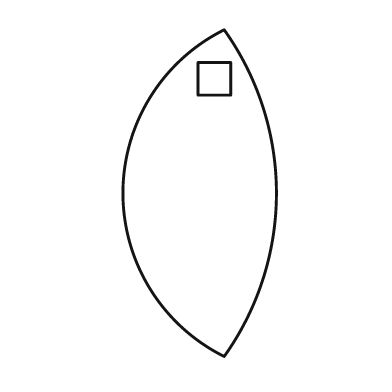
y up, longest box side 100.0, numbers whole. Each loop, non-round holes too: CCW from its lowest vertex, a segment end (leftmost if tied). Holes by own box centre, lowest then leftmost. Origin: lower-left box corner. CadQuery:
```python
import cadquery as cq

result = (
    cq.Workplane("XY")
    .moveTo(31.0, 0.0)
    .threePointArc((47.0, 50.0), (31.0, 100.0))
    .threePointArc((0.0, 50.0), (31.0, 0.0))
    .close()
    .moveTo(23.0, 80.0)
    .lineTo(33.0, 80.0)
    .lineTo(33.0, 90.0)
    .lineTo(23.0, 90.0)
    .close()
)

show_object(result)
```